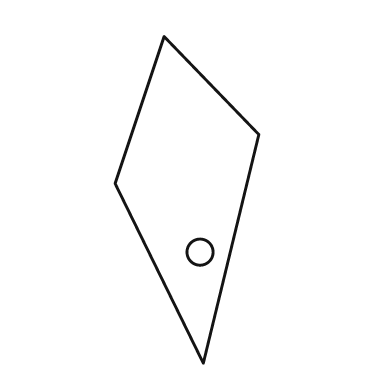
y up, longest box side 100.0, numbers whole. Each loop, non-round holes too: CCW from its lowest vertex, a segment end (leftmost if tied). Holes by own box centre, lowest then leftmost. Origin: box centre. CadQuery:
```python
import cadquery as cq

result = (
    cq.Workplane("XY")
    .moveTo(5.0, -50.0)
    .lineTo(22.0, 20.0)
    .lineTo(-7.0, 50.0)
    .lineTo(-22.0, 5.0)
    .close()
    .moveTo(4.0, -16.0)
    .circle(4.0)
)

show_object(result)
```